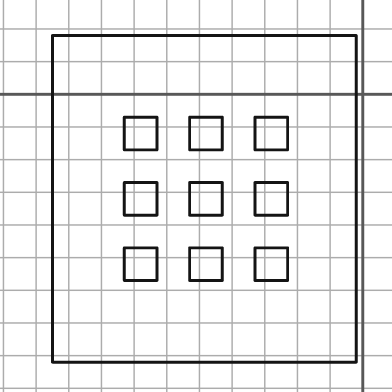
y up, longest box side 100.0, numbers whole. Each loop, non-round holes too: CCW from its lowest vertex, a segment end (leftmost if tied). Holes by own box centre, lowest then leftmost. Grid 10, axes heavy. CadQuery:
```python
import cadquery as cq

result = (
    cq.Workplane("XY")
    .moveTo(-95.0, -82.0)
    .lineTo(-2.0, -82.0)
    .lineTo(-2.0, 18.0)
    .lineTo(-95.0, 18.0)
    .close()
    .moveTo(-73.0, -57.0)
    .lineTo(-63.0, -57.0)
    .lineTo(-63.0, -47.0)
    .lineTo(-73.0, -47.0)
    .close()
    .moveTo(-53.0, -57.0)
    .lineTo(-43.0, -57.0)
    .lineTo(-43.0, -47.0)
    .lineTo(-53.0, -47.0)
    .close()
    .moveTo(-33.0, -57.0)
    .lineTo(-23.0, -57.0)
    .lineTo(-23.0, -47.0)
    .lineTo(-33.0, -47.0)
    .close()
    .moveTo(-73.0, -37.0)
    .lineTo(-63.0, -37.0)
    .lineTo(-63.0, -27.0)
    .lineTo(-73.0, -27.0)
    .close()
    .moveTo(-53.0, -37.0)
    .lineTo(-43.0, -37.0)
    .lineTo(-43.0, -27.0)
    .lineTo(-53.0, -27.0)
    .close()
    .moveTo(-33.0, -37.0)
    .lineTo(-23.0, -37.0)
    .lineTo(-23.0, -27.0)
    .lineTo(-33.0, -27.0)
    .close()
    .moveTo(-73.0, -17.0)
    .lineTo(-63.0, -17.0)
    .lineTo(-63.0, -7.0)
    .lineTo(-73.0, -7.0)
    .close()
    .moveTo(-53.0, -17.0)
    .lineTo(-43.0, -17.0)
    .lineTo(-43.0, -7.0)
    .lineTo(-53.0, -7.0)
    .close()
    .moveTo(-33.0, -17.0)
    .lineTo(-23.0, -17.0)
    .lineTo(-23.0, -7.0)
    .lineTo(-33.0, -7.0)
    .close()
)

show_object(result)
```